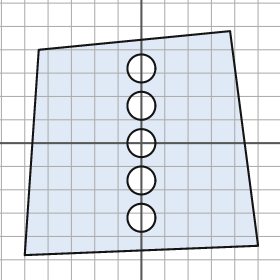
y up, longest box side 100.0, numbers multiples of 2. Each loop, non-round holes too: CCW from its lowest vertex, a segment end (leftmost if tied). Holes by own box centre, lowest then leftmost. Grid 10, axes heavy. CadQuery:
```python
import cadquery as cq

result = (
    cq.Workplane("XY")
    .moveTo(-50.0, -48.0)
    .lineTo(50.0, -44.0)
    .lineTo(38.0, 48.0)
    .lineTo(-44.0, 40.0)
    .close()
    .moveTo(0.0, -32.0)
    .circle(6.0)
    .moveTo(0.0, -16.0)
    .circle(6.0)
    .moveTo(0.0, 0.0)
    .circle(6.0)
    .moveTo(0.0, 16.0)
    .circle(6.0)
    .moveTo(0.0, 32.0)
    .circle(6.0)
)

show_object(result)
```